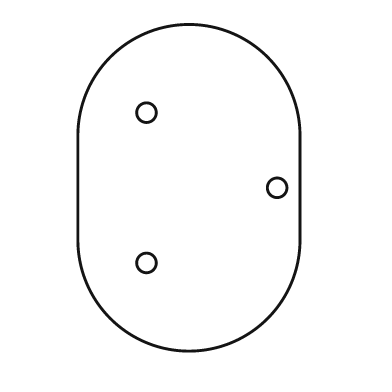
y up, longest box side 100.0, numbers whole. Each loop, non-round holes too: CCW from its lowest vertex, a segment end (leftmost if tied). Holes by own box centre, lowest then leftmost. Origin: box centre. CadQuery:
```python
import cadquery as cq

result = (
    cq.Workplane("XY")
    .moveTo(-34.0, -16.0)
    .threePointArc((0.0, -50.0), (34.0, -16.0))
    .lineTo(34.0, 16.0)
    .threePointArc((0.0, 50.0), (-34.0, 16.0))
    .close()
    .moveTo(-13.0, -23.0)
    .circle(3.0)
    .moveTo(27.0, 0.0)
    .circle(3.0)
    .moveTo(-13.0, 23.0)
    .circle(3.0)
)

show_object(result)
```